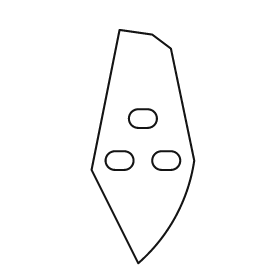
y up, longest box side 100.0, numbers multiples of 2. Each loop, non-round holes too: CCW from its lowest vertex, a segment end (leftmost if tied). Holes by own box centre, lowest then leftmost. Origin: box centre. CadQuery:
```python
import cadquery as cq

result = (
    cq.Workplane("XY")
    .moveTo(-2.0, -50.0)
    .threePointArc((14.0, -30.0), (22.0, -6.0))
    .lineTo(12.0, 42.0)
    .lineTo(4.0, 48.0)
    .lineTo(-10.0, 50.0)
    .lineTo(-22.0, -10.0)
    .close()
    .moveTo(-12.0, -10.0)
    .lineTo(-8.0, -10.0)
    .threePointArc((-4.0, -6.0), (-8.0, -2.0))
    .lineTo(-12.0, -2.0)
    .threePointArc((-16.0, -6.0), (-12.0, -10.0))
    .close()
    .moveTo(8.0, -10.0)
    .lineTo(12.0, -10.0)
    .threePointArc((16.0, -6.0), (12.0, -2.0))
    .lineTo(8.0, -2.0)
    .threePointArc((4.0, -6.0), (8.0, -10.0))
    .close()
    .moveTo(-2.0, 8.0)
    .lineTo(2.0, 8.0)
    .threePointArc((6.0, 12.0), (2.0, 16.0))
    .lineTo(-2.0, 16.0)
    .threePointArc((-6.0, 12.0), (-2.0, 8.0))
    .close()
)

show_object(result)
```